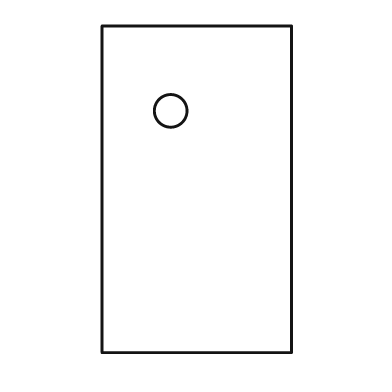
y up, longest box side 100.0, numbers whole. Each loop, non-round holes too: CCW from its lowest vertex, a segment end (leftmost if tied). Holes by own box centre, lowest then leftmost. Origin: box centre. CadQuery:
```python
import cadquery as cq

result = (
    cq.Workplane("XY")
    .moveTo(-29.0, -50.0)
    .lineTo(29.0, -50.0)
    .lineTo(29.0, 50.0)
    .lineTo(-29.0, 50.0)
    .close()
    .moveTo(-8.0, 24.0)
    .circle(5.0)
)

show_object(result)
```